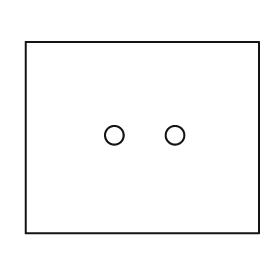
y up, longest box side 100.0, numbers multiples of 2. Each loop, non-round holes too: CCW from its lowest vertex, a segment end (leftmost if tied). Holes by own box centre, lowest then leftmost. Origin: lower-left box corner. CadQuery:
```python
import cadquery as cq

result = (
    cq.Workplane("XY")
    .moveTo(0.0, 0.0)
    .lineTo(100.0, 0.0)
    .lineTo(100.0, 82.0)
    .lineTo(0.0, 82.0)
    .close()
    .moveTo(38.0, 42.0)
    .circle(4.0)
    .moveTo(64.0, 42.0)
    .circle(4.0)
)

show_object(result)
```